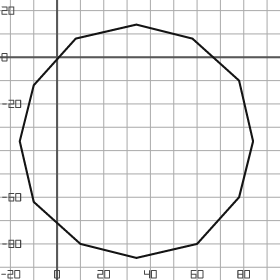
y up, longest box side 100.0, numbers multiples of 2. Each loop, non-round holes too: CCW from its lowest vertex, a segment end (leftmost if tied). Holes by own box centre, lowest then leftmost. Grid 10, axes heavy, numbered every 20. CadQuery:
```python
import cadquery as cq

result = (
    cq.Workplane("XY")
    .moveTo(34.0, -86.0)
    .lineTo(60.0, -80.0)
    .lineTo(78.0, -60.0)
    .lineTo(84.0, -36.0)
    .lineTo(78.0, -10.0)
    .lineTo(58.0, 8.0)
    .lineTo(34.0, 14.0)
    .lineTo(8.0, 8.0)
    .lineTo(-10.0, -12.0)
    .lineTo(-16.0, -36.0)
    .lineTo(-10.0, -62.0)
    .lineTo(10.0, -80.0)
    .close()
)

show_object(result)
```